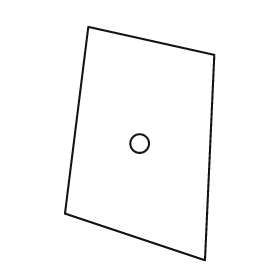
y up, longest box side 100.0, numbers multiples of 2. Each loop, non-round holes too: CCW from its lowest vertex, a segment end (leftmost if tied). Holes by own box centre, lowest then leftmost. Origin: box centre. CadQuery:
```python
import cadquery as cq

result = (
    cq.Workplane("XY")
    .moveTo(28.0, -50.0)
    .lineTo(32.0, 38.0)
    .lineTo(-22.0, 50.0)
    .lineTo(-32.0, -30.0)
    .close()
    .moveTo(0.0, 0.0)
    .circle(4.0)
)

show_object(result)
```